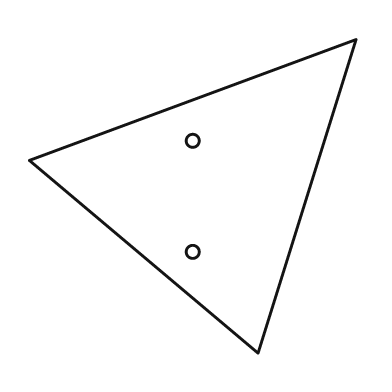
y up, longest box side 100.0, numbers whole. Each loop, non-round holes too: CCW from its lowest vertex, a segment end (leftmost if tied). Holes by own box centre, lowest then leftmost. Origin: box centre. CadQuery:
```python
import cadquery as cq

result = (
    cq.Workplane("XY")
    .moveTo(20.0, -48.0)
    .lineTo(50.0, 48.0)
    .lineTo(-50.0, 11.0)
    .close()
    .moveTo(0.0, -17.0)
    .circle(2.0)
    .moveTo(0.0, 17.0)
    .circle(2.0)
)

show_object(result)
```